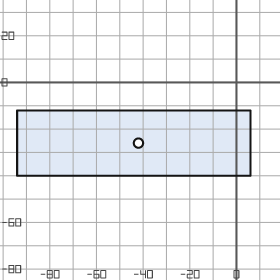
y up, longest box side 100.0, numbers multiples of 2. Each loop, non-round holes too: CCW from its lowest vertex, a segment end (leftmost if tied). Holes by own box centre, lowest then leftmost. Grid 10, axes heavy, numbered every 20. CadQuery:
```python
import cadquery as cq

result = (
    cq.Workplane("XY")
    .moveTo(-94.0, -40.0)
    .lineTo(6.0, -40.0)
    .lineTo(6.0, -12.0)
    .lineTo(-94.0, -12.0)
    .close()
    .moveTo(-42.0, -26.0)
    .circle(2.0)
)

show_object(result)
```